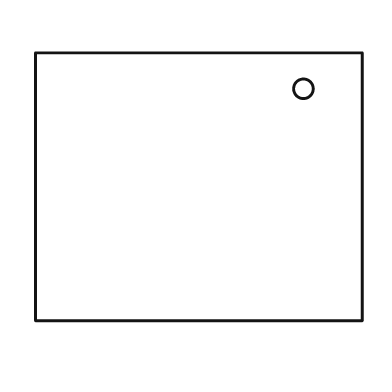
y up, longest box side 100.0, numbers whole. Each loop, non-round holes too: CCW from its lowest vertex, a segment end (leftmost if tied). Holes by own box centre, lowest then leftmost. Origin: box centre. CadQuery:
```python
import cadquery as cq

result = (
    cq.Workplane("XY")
    .moveTo(-50.0, -41.0)
    .lineTo(50.0, -41.0)
    .lineTo(50.0, 41.0)
    .lineTo(-50.0, 41.0)
    .close()
    .moveTo(32.0, 30.0)
    .circle(3.0)
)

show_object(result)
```